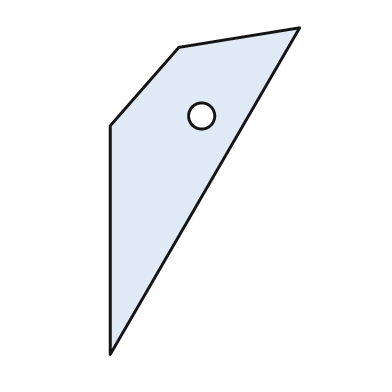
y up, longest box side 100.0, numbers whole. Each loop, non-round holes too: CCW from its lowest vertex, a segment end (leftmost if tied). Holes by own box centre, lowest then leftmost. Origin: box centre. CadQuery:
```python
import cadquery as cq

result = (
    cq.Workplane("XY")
    .moveTo(-29.0, -50.0)
    .lineTo(29.0, 50.0)
    .lineTo(-8.0, 44.0)
    .lineTo(-29.0, 20.0)
    .close()
    .moveTo(-1.0, 23.0)
    .circle(4.0)
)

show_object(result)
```